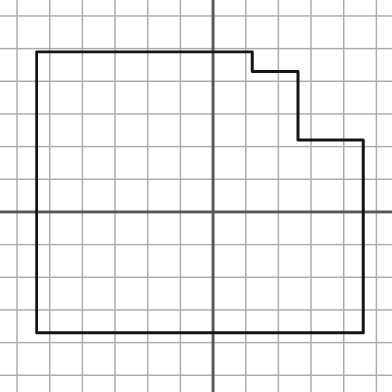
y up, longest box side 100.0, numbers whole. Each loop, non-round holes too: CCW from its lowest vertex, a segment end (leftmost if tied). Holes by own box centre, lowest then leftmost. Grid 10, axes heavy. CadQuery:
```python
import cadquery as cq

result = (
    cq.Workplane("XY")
    .moveTo(-54.0, -37.0)
    .lineTo(46.0, -37.0)
    .lineTo(46.0, 22.0)
    .lineTo(26.0, 22.0)
    .lineTo(26.0, 43.0)
    .lineTo(12.0, 43.0)
    .lineTo(12.0, 49.0)
    .lineTo(-54.0, 49.0)
    .close()
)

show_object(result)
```